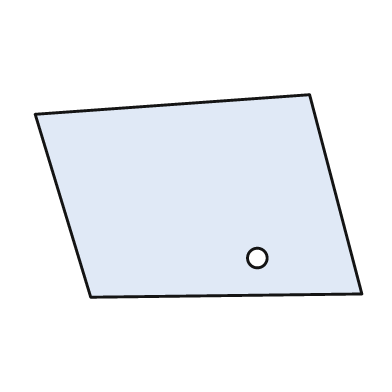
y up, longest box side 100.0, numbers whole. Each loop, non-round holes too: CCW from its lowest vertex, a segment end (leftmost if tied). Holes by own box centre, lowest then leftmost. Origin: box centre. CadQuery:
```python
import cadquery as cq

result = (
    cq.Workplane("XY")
    .moveTo(-33.0, -31.0)
    .lineTo(50.0, -30.0)
    .lineTo(34.0, 31.0)
    .lineTo(-50.0, 25.0)
    .close()
    .moveTo(18.0, -19.0)
    .circle(3.0)
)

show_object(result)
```